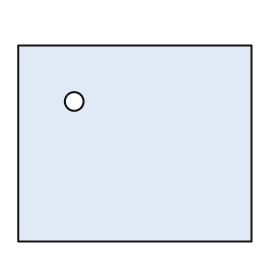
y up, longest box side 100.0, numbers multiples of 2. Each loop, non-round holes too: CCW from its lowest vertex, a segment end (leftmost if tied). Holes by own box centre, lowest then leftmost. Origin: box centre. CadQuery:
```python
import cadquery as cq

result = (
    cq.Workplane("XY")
    .moveTo(-50.0, -42.0)
    .lineTo(50.0, -42.0)
    .lineTo(50.0, 42.0)
    .lineTo(-50.0, 42.0)
    .close()
    .moveTo(-26.0, 18.0)
    .circle(4.0)
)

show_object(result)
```